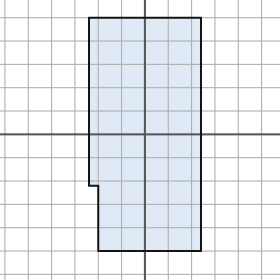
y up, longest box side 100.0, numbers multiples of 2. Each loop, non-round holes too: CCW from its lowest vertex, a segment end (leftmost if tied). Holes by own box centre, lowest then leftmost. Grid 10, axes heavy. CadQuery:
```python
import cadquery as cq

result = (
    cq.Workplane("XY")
    .moveTo(-20.0, -50.0)
    .lineTo(24.0, -50.0)
    .lineTo(24.0, 50.0)
    .lineTo(-24.0, 50.0)
    .lineTo(-24.0, -22.0)
    .lineTo(-20.0, -22.0)
    .close()
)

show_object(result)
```